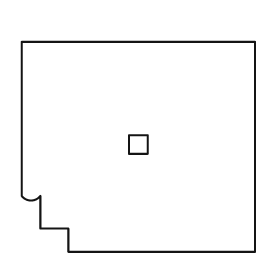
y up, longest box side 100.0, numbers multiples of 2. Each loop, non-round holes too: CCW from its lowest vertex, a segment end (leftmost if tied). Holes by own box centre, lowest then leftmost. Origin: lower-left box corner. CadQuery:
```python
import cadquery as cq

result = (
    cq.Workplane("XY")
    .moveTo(20.0, 0.0)
    .lineTo(100.0, 0.0)
    .lineTo(100.0, 90.0)
    .lineTo(0.0, 90.0)
    .lineTo(0.0, 24.0)
    .threePointArc((4.0, 22.0), (8.0, 24.0))
    .lineTo(8.0, 10.0)
    .lineTo(20.0, 10.0)
    .close()
    .moveTo(46.0, 42.0)
    .lineTo(54.0, 42.0)
    .lineTo(54.0, 50.0)
    .lineTo(46.0, 50.0)
    .close()
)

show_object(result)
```